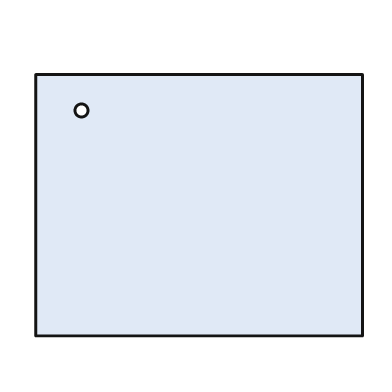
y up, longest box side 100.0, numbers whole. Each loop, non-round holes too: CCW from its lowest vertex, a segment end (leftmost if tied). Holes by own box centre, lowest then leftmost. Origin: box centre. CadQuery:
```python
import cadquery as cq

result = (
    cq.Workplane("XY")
    .moveTo(-50.0, -40.0)
    .lineTo(50.0, -40.0)
    .lineTo(50.0, 40.0)
    .lineTo(-50.0, 40.0)
    .close()
    .moveTo(-36.0, 29.0)
    .circle(2.0)
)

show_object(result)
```